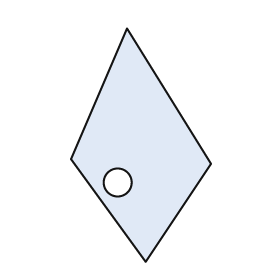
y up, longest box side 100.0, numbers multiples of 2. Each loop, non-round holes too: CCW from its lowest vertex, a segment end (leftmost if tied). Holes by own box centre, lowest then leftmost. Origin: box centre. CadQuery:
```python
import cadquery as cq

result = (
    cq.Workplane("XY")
    .moveTo(2.0, -50.0)
    .lineTo(30.0, -8.0)
    .lineTo(-6.0, 50.0)
    .lineTo(-30.0, -6.0)
    .close()
    .moveTo(-10.0, -16.0)
    .circle(6.0)
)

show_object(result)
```